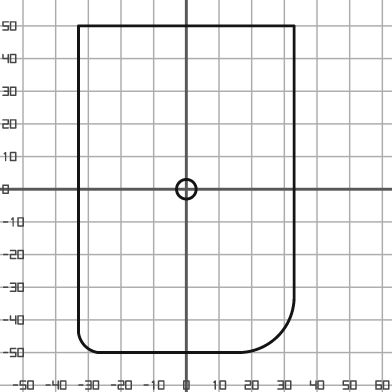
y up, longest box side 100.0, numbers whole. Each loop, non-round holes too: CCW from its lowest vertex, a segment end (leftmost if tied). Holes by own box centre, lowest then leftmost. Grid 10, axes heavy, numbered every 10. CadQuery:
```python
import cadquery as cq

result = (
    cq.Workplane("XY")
    .moveTo(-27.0, -50.0)
    .lineTo(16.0, -50.0)
    .threePointArc((28.0, -45.0), (33.0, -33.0))
    .lineTo(33.0, 50.0)
    .lineTo(-33.0, 50.0)
    .lineTo(-33.0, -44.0)
    .threePointArc((-31.0, -48.0), (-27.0, -50.0))
    .close()
    .moveTo(0.0, 0.0)
    .circle(3.0)
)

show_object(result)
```